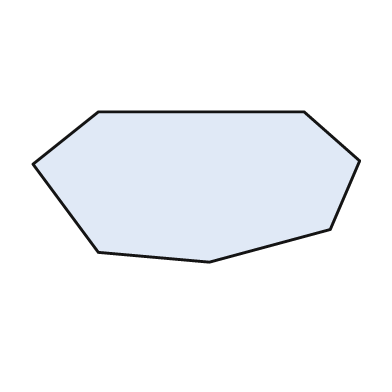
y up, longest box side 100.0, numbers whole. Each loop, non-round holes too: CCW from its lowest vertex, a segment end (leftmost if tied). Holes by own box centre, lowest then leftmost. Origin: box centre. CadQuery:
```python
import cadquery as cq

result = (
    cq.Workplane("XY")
    .moveTo(4.0, -23.0)
    .lineTo(41.0, -13.0)
    .lineTo(50.0, 8.0)
    .lineTo(33.0, 23.0)
    .lineTo(-30.0, 23.0)
    .lineTo(-50.0, 7.0)
    .lineTo(-30.0, -20.0)
    .close()
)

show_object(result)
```